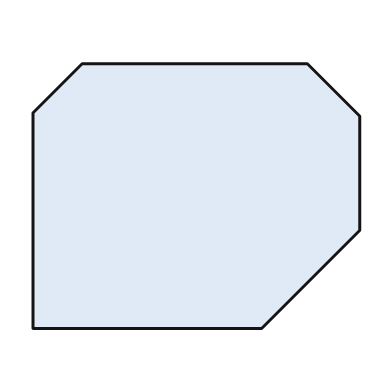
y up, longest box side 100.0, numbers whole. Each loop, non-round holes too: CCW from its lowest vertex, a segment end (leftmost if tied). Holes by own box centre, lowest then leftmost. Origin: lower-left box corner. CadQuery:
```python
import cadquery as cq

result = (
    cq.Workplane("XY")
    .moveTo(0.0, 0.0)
    .lineTo(70.0, 0.0)
    .lineTo(100.0, 30.0)
    .lineTo(100.0, 65.0)
    .lineTo(84.0, 81.0)
    .lineTo(15.0, 81.0)
    .lineTo(0.0, 66.0)
    .close()
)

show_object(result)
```